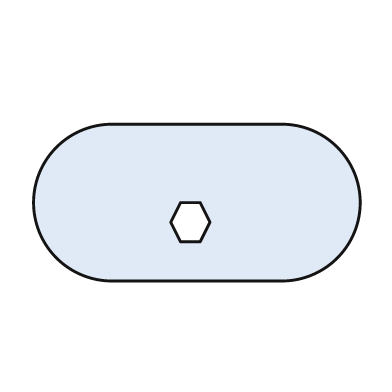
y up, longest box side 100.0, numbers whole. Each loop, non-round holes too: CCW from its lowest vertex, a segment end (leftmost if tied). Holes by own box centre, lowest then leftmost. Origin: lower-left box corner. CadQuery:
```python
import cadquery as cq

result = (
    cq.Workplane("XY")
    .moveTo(24.0, 0.0)
    .lineTo(76.0, 0.0)
    .threePointArc((100.0, 24.0), (76.0, 48.0))
    .lineTo(24.0, 48.0)
    .threePointArc((0.0, 24.0), (24.0, 0.0))
    .close()
    .moveTo(45.0, 12.0)
    .lineTo(51.0, 12.0)
    .lineTo(54.0, 18.0)
    .lineTo(51.0, 24.0)
    .lineTo(45.0, 24.0)
    .lineTo(42.0, 18.0)
    .close()
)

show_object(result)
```